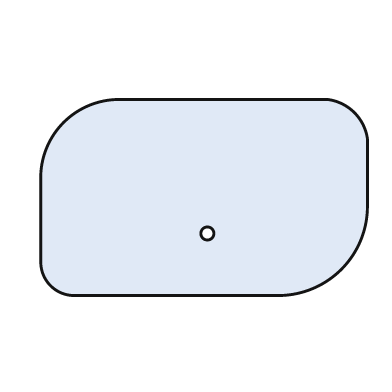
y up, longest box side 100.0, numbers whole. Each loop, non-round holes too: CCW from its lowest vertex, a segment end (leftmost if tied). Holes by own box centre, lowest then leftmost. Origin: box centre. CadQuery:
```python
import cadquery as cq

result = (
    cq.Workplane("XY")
    .moveTo(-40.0, -30.0)
    .lineTo(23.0, -30.0)
    .threePointArc((42.0, -22.0), (50.0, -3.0))
    .lineTo(50.0, 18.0)
    .threePointArc((46.0, 26.0), (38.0, 30.0))
    .lineTo(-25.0, 30.0)
    .threePointArc((-43.0, 23.0), (-50.0, 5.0))
    .lineTo(-50.0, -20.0)
    .threePointArc((-47.0, -27.0), (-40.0, -30.0))
    .close()
    .moveTo(1.0, -11.0)
    .circle(2.0)
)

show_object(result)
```